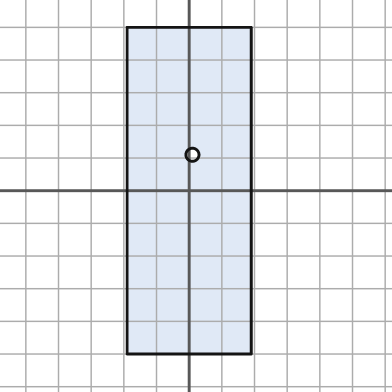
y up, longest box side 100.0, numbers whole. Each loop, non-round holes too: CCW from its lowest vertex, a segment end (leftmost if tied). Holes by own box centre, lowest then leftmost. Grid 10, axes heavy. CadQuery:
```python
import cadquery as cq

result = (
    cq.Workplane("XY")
    .moveTo(-19.0, -50.0)
    .lineTo(19.0, -50.0)
    .lineTo(19.0, 50.0)
    .lineTo(-19.0, 50.0)
    .close()
    .moveTo(1.0, 11.0)
    .circle(2.0)
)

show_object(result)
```